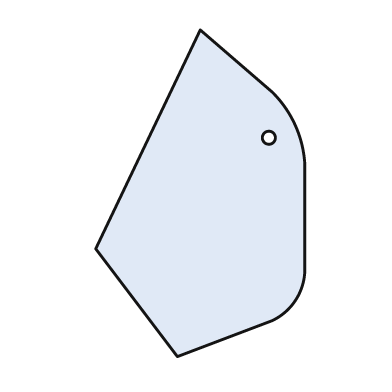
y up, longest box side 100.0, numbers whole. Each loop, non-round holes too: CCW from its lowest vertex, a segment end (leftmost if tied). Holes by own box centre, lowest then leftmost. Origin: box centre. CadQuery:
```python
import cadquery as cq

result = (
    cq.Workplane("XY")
    .moveTo(-7.0, -50.0)
    .lineTo(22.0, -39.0)
    .threePointArc((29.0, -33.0), (32.0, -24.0))
    .lineTo(32.0, 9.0)
    .threePointArc((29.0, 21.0), (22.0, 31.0))
    .lineTo(0.0, 50.0)
    .lineTo(-32.0, -17.0)
    .close()
    .moveTo(21.0, 17.0)
    .circle(2.0)
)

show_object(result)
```